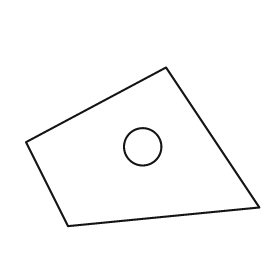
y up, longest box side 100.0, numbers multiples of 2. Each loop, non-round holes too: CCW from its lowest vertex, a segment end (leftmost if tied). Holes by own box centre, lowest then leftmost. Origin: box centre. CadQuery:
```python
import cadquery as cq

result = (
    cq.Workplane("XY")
    .moveTo(-32.0, -34.0)
    .lineTo(50.0, -26.0)
    .lineTo(10.0, 34.0)
    .lineTo(-50.0, 2.0)
    .close()
    .moveTo(0.0, 0.0)
    .circle(8.0)
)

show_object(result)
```